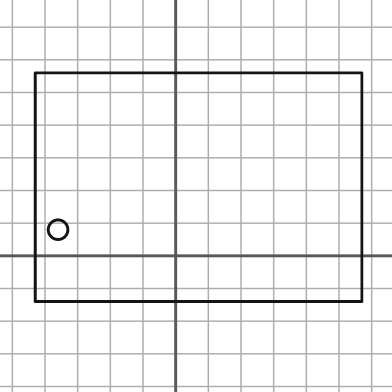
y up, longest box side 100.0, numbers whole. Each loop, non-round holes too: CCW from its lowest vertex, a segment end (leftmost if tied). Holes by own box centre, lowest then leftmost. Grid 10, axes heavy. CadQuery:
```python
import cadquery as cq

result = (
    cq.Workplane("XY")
    .moveTo(-43.0, -14.0)
    .lineTo(57.0, -14.0)
    .lineTo(57.0, 56.0)
    .lineTo(-43.0, 56.0)
    .close()
    .moveTo(-36.0, 8.0)
    .circle(3.0)
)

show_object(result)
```